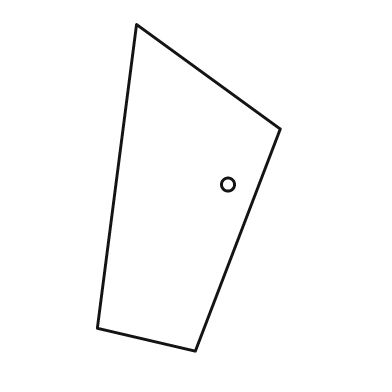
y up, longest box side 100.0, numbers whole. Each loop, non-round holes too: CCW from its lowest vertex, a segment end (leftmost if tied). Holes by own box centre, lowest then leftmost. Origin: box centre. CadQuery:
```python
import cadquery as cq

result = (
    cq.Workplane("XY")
    .moveTo(2.0, -50.0)
    .lineTo(28.0, 18.0)
    .lineTo(-16.0, 50.0)
    .lineTo(-28.0, -43.0)
    .close()
    .moveTo(12.0, 1.0)
    .circle(2.0)
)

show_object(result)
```